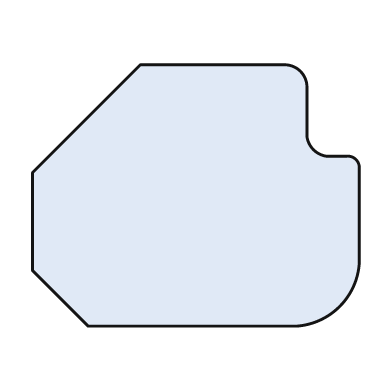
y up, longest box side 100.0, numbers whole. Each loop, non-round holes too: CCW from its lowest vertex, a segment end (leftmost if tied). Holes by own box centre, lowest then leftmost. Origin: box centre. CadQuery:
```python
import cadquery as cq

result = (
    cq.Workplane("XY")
    .moveTo(-33.0, -40.0)
    .lineTo(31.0, -40.0)
    .threePointArc((44.0, -34.0), (50.0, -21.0))
    .lineTo(50.0, 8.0)
    .threePointArc((49.0, 11.0), (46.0, 12.0))
    .lineTo(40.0, 12.0)
    .threePointArc((36.0, 14.0), (34.0, 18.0))
    .lineTo(34.0, 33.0)
    .threePointArc((32.0, 38.0), (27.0, 40.0))
    .lineTo(-17.0, 40.0)
    .lineTo(-50.0, 7.0)
    .lineTo(-50.0, -23.0)
    .close()
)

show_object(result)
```